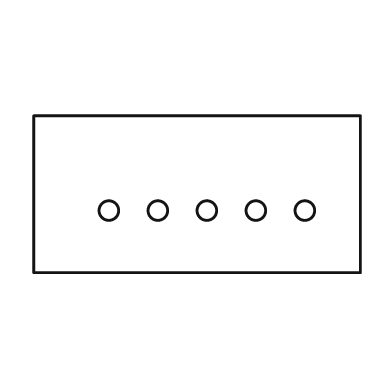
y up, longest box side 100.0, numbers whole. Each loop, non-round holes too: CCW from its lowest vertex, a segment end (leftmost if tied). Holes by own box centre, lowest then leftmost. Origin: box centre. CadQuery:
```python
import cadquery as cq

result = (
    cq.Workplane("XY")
    .moveTo(-50.0, -24.0)
    .lineTo(50.0, -24.0)
    .lineTo(50.0, 24.0)
    .lineTo(-50.0, 24.0)
    .close()
    .moveTo(-27.0, -5.0)
    .circle(3.0)
    .moveTo(-12.0, -5.0)
    .circle(3.0)
    .moveTo(3.0, -5.0)
    .circle(3.0)
    .moveTo(18.0, -5.0)
    .circle(3.0)
    .moveTo(33.0, -5.0)
    .circle(3.0)
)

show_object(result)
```